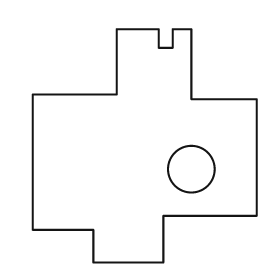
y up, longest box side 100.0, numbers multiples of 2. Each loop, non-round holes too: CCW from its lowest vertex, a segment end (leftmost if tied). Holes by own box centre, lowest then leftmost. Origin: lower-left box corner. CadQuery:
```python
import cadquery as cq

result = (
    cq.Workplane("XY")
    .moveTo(26.0, 0.0)
    .lineTo(56.0, 0.0)
    .lineTo(56.0, 20.0)
    .lineTo(96.0, 20.0)
    .lineTo(96.0, 70.0)
    .lineTo(68.0, 70.0)
    .lineTo(68.0, 100.0)
    .lineTo(60.0, 100.0)
    .lineTo(60.0, 92.0)
    .lineTo(54.0, 92.0)
    .lineTo(54.0, 100.0)
    .lineTo(36.0, 100.0)
    .lineTo(36.0, 72.0)
    .lineTo(0.0, 72.0)
    .lineTo(0.0, 14.0)
    .lineTo(26.0, 14.0)
    .close()
    .moveTo(68.0, 40.0)
    .circle(10.0)
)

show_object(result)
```